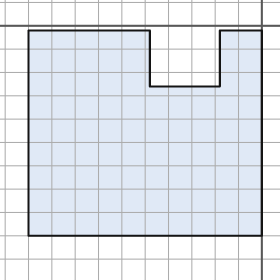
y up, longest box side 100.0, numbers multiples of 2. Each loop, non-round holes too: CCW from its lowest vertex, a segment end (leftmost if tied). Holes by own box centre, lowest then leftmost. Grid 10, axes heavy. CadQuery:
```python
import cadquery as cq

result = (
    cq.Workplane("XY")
    .moveTo(-100.0, -90.0)
    .lineTo(0.0, -90.0)
    .lineTo(0.0, -2.0)
    .lineTo(-18.0, -2.0)
    .lineTo(-18.0, -26.0)
    .lineTo(-48.0, -26.0)
    .lineTo(-48.0, -2.0)
    .lineTo(-100.0, -2.0)
    .close()
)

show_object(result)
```